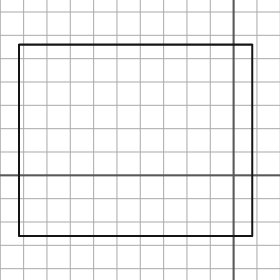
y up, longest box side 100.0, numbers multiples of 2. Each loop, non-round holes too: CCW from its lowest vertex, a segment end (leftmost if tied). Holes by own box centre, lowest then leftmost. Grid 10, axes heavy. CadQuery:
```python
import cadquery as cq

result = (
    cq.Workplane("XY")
    .moveTo(-92.0, -26.0)
    .lineTo(8.0, -26.0)
    .lineTo(8.0, 56.0)
    .lineTo(-92.0, 56.0)
    .close()
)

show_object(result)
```